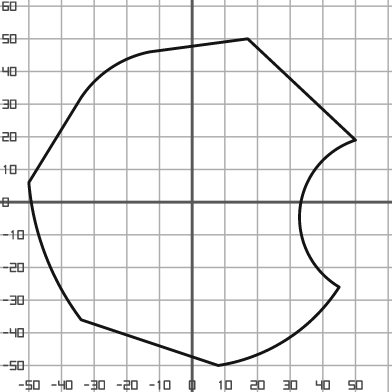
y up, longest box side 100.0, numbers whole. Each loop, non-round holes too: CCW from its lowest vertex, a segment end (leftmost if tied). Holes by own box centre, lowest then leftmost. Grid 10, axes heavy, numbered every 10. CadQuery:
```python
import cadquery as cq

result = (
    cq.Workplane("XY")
    .moveTo(8.0, -50.0)
    .threePointArc((29.0, -42.0), (45.0, -26.0))
    .threePointArc((33.0, -2.0), (50.0, 19.0))
    .lineTo(17.0, 50.0)
    .lineTo(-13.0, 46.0)
    .threePointArc((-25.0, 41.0), (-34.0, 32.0))
    .lineTo(-50.0, 6.0)
    .threePointArc((-45.0, -16.0), (-34.0, -36.0))
    .close()
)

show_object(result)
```